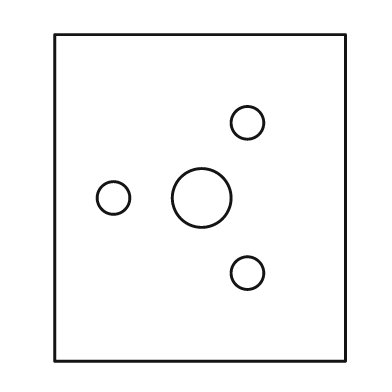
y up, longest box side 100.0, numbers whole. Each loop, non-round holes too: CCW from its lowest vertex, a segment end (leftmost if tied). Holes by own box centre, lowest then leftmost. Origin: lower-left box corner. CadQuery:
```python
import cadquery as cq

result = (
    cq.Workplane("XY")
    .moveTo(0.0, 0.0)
    .lineTo(89.0, 0.0)
    .lineTo(89.0, 100.0)
    .lineTo(0.0, 100.0)
    .close()
    .moveTo(59.0, 27.0)
    .circle(5.0)
    .moveTo(18.0, 50.0)
    .circle(5.0)
    .moveTo(45.0, 50.0)
    .circle(9.0)
    .moveTo(59.0, 73.0)
    .circle(5.0)
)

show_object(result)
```